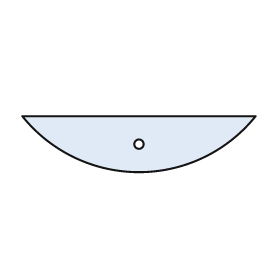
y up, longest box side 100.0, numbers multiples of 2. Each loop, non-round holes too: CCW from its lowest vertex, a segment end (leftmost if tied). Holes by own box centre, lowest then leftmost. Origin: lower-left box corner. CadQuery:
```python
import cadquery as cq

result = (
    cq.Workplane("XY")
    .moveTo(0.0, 24.0)
    .threePointArc((50.0, 0.0), (100.0, 24.0))
    .close()
    .moveTo(50.0, 12.0)
    .circle(2.0)
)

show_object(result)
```